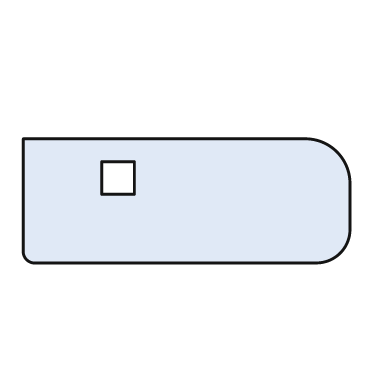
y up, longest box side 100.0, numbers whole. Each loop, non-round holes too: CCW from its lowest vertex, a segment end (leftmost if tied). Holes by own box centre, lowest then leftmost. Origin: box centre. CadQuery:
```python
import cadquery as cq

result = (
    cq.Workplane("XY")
    .moveTo(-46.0, -19.0)
    .lineTo(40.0, -19.0)
    .threePointArc((47.0, -16.0), (50.0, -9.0))
    .lineTo(50.0, 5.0)
    .threePointArc((46.0, 15.0), (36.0, 19.0))
    .lineTo(-50.0, 19.0)
    .lineTo(-50.0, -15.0)
    .threePointArc((-49.0, -18.0), (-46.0, -19.0))
    .close()
    .moveTo(-26.0, 2.0)
    .lineTo(-16.0, 2.0)
    .lineTo(-16.0, 12.0)
    .lineTo(-26.0, 12.0)
    .close()
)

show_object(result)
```